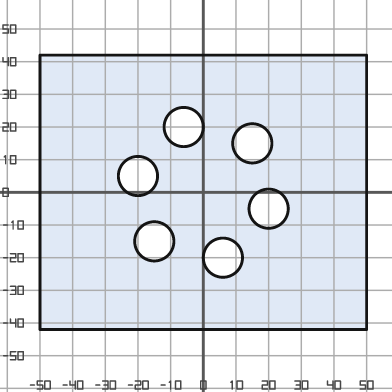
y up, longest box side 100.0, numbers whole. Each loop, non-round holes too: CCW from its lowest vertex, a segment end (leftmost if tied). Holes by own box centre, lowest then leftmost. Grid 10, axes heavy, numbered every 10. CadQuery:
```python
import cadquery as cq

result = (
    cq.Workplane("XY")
    .moveTo(-50.0, -42.0)
    .lineTo(50.0, -42.0)
    .lineTo(50.0, 42.0)
    .lineTo(-50.0, 42.0)
    .close()
    .moveTo(6.0, -20.0)
    .circle(6.0)
    .moveTo(-15.0, -15.0)
    .circle(6.0)
    .moveTo(20.0, -5.0)
    .circle(6.0)
    .moveTo(-20.0, 5.0)
    .circle(6.0)
    .moveTo(15.0, 15.0)
    .circle(6.0)
    .moveTo(-6.0, 20.0)
    .circle(6.0)
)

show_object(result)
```